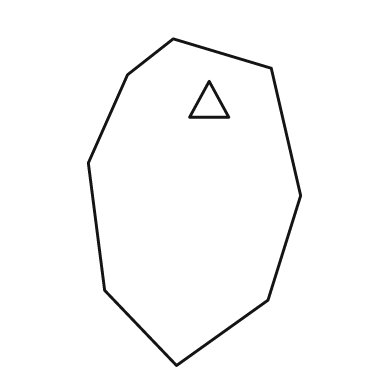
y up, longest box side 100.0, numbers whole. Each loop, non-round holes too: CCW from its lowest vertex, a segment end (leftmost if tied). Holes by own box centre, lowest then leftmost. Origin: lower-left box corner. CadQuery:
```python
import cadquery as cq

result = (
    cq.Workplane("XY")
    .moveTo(27.0, 0.0)
    .lineTo(55.0, 20.0)
    .lineTo(65.0, 52.0)
    .lineTo(56.0, 91.0)
    .lineTo(26.0, 100.0)
    .lineTo(12.0, 89.0)
    .lineTo(0.0, 62.0)
    .lineTo(5.0, 23.0)
    .close()
    .moveTo(31.0, 76.0)
    .lineTo(43.0, 76.0)
    .lineTo(37.0, 87.0)
    .close()
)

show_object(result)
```